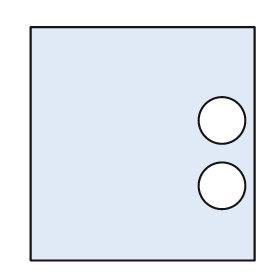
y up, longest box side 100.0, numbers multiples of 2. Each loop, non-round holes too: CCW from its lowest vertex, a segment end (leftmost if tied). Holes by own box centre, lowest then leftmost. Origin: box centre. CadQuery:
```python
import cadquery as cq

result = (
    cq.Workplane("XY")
    .moveTo(-48.0, -50.0)
    .lineTo(48.0, -50.0)
    .lineTo(48.0, 50.0)
    .lineTo(-48.0, 50.0)
    .close()
    .moveTo(34.0, -18.0)
    .circle(10.0)
    .moveTo(34.0, 10.0)
    .circle(10.0)
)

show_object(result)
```